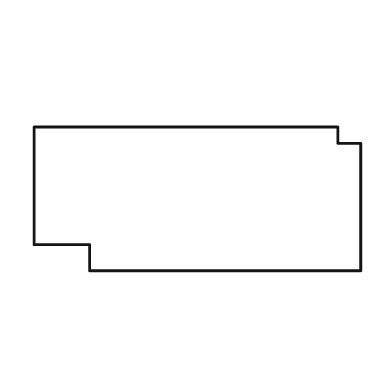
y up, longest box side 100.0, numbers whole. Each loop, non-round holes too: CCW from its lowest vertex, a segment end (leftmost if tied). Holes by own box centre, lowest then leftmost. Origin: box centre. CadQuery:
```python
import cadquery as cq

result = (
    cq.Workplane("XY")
    .moveTo(-33.0, -22.0)
    .lineTo(50.0, -22.0)
    .lineTo(50.0, 17.0)
    .lineTo(43.0, 17.0)
    .lineTo(43.0, 22.0)
    .lineTo(-50.0, 22.0)
    .lineTo(-50.0, -14.0)
    .lineTo(-33.0, -14.0)
    .close()
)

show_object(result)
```